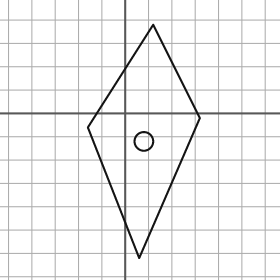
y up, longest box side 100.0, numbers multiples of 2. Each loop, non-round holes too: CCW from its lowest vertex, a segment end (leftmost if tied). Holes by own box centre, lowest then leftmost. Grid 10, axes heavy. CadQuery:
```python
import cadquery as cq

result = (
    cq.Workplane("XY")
    .moveTo(6.0, -62.0)
    .lineTo(32.0, -2.0)
    .lineTo(12.0, 38.0)
    .lineTo(-16.0, -6.0)
    .close()
    .moveTo(8.0, -12.0)
    .circle(4.0)
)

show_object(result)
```